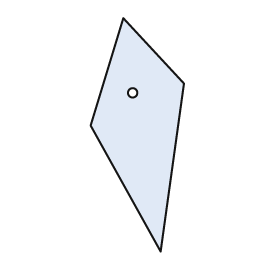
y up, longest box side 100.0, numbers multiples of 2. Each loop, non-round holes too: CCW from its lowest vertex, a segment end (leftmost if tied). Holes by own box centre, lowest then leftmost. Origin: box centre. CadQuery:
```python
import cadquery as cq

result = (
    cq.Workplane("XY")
    .moveTo(10.0, -50.0)
    .lineTo(20.0, 22.0)
    .lineTo(-6.0, 50.0)
    .lineTo(-20.0, 4.0)
    .close()
    .moveTo(-2.0, 18.0)
    .circle(2.0)
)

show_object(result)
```